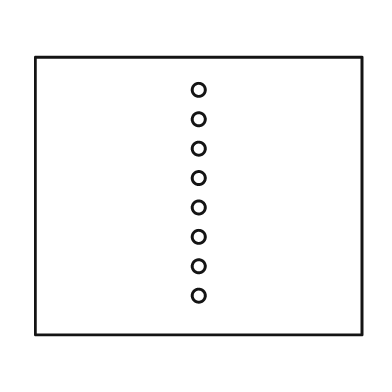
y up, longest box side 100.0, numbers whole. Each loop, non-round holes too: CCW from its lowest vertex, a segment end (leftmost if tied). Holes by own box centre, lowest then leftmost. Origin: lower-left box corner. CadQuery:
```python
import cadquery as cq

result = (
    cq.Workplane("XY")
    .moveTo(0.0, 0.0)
    .lineTo(100.0, 0.0)
    .lineTo(100.0, 85.0)
    .lineTo(0.0, 85.0)
    .close()
    .moveTo(50.0, 12.0)
    .circle(2.0)
    .moveTo(50.0, 21.0)
    .circle(2.0)
    .moveTo(50.0, 30.0)
    .circle(2.0)
    .moveTo(50.0, 39.0)
    .circle(2.0)
    .moveTo(50.0, 48.0)
    .circle(2.0)
    .moveTo(50.0, 57.0)
    .circle(2.0)
    .moveTo(50.0, 66.0)
    .circle(2.0)
    .moveTo(50.0, 75.0)
    .circle(2.0)
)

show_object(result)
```